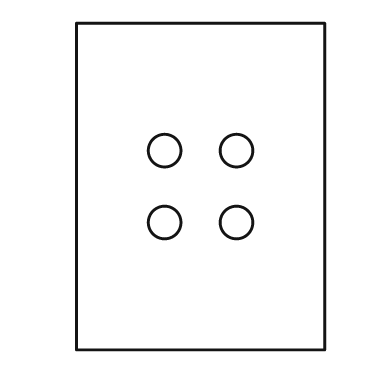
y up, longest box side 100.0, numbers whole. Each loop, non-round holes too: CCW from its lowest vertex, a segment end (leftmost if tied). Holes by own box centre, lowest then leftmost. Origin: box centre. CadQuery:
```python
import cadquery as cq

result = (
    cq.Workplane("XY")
    .moveTo(-38.0, -50.0)
    .lineTo(38.0, -50.0)
    .lineTo(38.0, 50.0)
    .lineTo(-38.0, 50.0)
    .close()
    .moveTo(-11.0, -11.0)
    .circle(5.0)
    .moveTo(11.0, -11.0)
    .circle(5.0)
    .moveTo(-11.0, 11.0)
    .circle(5.0)
    .moveTo(11.0, 11.0)
    .circle(5.0)
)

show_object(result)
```